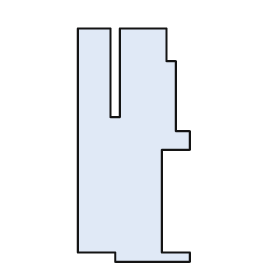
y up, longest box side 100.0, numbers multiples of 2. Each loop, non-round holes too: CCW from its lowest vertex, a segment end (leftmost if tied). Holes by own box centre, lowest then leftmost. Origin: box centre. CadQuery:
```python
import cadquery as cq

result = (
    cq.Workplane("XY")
    .moveTo(-8.0, -50.0)
    .lineTo(24.0, -50.0)
    .lineTo(24.0, -46.0)
    .lineTo(12.0, -46.0)
    .lineTo(12.0, -2.0)
    .lineTo(24.0, -2.0)
    .lineTo(24.0, 6.0)
    .lineTo(18.0, 6.0)
    .lineTo(18.0, 36.0)
    .lineTo(14.0, 36.0)
    .lineTo(14.0, 50.0)
    .lineTo(-6.0, 50.0)
    .lineTo(-6.0, 12.0)
    .lineTo(-10.0, 12.0)
    .lineTo(-10.0, 50.0)
    .lineTo(-24.0, 50.0)
    .lineTo(-24.0, -46.0)
    .lineTo(-8.0, -46.0)
    .close()
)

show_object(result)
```